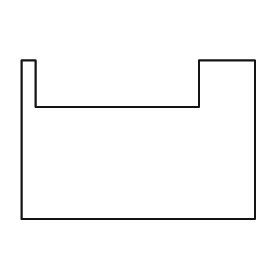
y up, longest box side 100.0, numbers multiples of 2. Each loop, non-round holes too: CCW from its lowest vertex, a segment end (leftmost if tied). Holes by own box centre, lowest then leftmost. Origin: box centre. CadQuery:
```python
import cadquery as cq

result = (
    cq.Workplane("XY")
    .moveTo(-50.0, -34.0)
    .lineTo(50.0, -34.0)
    .lineTo(50.0, 34.0)
    .lineTo(26.0, 34.0)
    .lineTo(26.0, 14.0)
    .lineTo(-44.0, 14.0)
    .lineTo(-44.0, 34.0)
    .lineTo(-50.0, 34.0)
    .close()
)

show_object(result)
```